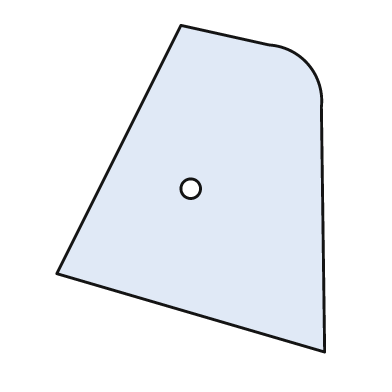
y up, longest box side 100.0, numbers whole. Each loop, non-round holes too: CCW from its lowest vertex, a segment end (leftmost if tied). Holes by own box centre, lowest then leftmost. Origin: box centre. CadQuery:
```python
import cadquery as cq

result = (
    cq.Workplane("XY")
    .moveTo(41.0, -50.0)
    .lineTo(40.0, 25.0)
    .threePointArc((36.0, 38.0), (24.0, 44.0))
    .lineTo(-3.0, 50.0)
    .lineTo(-41.0, -26.0)
    .close()
    .moveTo(0.0, 0.0)
    .circle(3.0)
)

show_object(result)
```